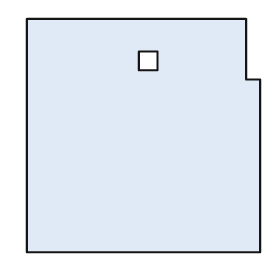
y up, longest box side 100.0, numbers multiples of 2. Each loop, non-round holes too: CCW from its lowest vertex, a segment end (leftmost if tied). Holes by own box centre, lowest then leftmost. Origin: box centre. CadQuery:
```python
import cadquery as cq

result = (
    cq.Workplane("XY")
    .moveTo(-50.0, -50.0)
    .lineTo(50.0, -50.0)
    .lineTo(50.0, 24.0)
    .lineTo(44.0, 24.0)
    .lineTo(44.0, 50.0)
    .lineTo(-50.0, 50.0)
    .close()
    .moveTo(-2.0, 28.0)
    .lineTo(6.0, 28.0)
    .lineTo(6.0, 36.0)
    .lineTo(-2.0, 36.0)
    .close()
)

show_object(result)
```